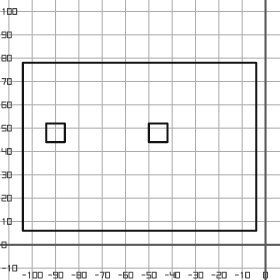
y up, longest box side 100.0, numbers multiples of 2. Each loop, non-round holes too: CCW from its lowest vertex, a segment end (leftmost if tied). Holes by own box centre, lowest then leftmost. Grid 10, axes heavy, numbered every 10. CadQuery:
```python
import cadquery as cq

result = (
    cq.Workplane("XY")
    .moveTo(-104.0, 6.0)
    .lineTo(-4.0, 6.0)
    .lineTo(-4.0, 78.0)
    .lineTo(-104.0, 78.0)
    .close()
    .moveTo(-94.0, 44.0)
    .lineTo(-86.0, 44.0)
    .lineTo(-86.0, 52.0)
    .lineTo(-94.0, 52.0)
    .close()
    .moveTo(-50.0, 44.0)
    .lineTo(-42.0, 44.0)
    .lineTo(-42.0, 52.0)
    .lineTo(-50.0, 52.0)
    .close()
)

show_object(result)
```